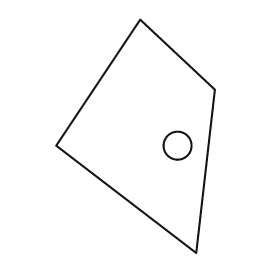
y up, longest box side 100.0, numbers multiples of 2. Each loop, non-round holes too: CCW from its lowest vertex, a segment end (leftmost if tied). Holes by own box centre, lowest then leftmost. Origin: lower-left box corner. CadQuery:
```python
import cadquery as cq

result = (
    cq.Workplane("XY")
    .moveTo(60.0, 0.0)
    .lineTo(68.0, 70.0)
    .lineTo(36.0, 100.0)
    .lineTo(0.0, 46.0)
    .close()
    .moveTo(52.0, 46.0)
    .circle(6.0)
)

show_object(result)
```